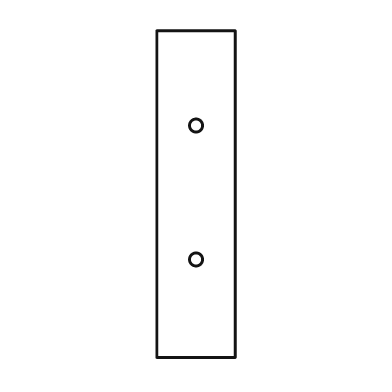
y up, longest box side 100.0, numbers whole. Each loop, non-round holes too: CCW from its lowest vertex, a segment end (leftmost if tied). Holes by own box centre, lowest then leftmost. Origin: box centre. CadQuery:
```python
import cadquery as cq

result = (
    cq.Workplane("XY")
    .moveTo(-12.0, -50.0)
    .lineTo(12.0, -50.0)
    .lineTo(12.0, 50.0)
    .lineTo(-12.0, 50.0)
    .close()
    .moveTo(0.0, -20.0)
    .circle(2.0)
    .moveTo(0.0, 21.0)
    .circle(2.0)
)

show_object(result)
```